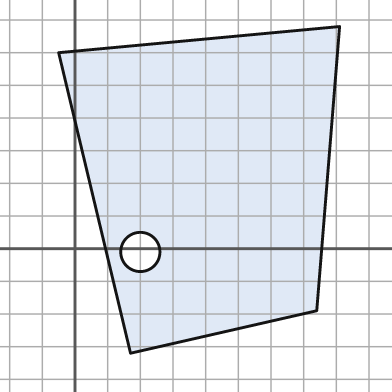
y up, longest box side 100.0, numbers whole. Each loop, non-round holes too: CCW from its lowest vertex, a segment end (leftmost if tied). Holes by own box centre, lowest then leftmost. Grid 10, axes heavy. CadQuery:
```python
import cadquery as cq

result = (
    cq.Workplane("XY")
    .moveTo(17.0, -32.0)
    .lineTo(74.0, -19.0)
    .lineTo(81.0, 68.0)
    .lineTo(-5.0, 60.0)
    .close()
    .moveTo(20.0, -1.0)
    .circle(6.0)
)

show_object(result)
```